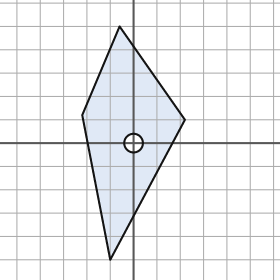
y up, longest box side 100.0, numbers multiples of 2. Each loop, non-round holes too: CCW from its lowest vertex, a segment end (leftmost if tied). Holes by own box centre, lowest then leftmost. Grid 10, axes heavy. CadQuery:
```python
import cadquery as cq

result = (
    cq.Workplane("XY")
    .moveTo(-10.0, -50.0)
    .lineTo(22.0, 10.0)
    .lineTo(-6.0, 50.0)
    .lineTo(-22.0, 12.0)
    .close()
    .moveTo(0.0, 0.0)
    .circle(4.0)
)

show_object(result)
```